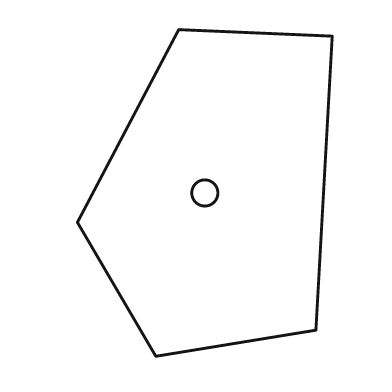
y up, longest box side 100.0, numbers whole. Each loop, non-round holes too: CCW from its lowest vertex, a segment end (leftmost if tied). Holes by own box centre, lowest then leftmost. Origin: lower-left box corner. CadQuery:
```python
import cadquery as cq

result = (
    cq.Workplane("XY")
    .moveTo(24.0, 0.0)
    .lineTo(73.0, 8.0)
    .lineTo(78.0, 98.0)
    .lineTo(31.0, 100.0)
    .lineTo(0.0, 41.0)
    .close()
    .moveTo(39.0, 50.0)
    .circle(4.0)
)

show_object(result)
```